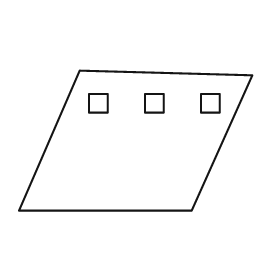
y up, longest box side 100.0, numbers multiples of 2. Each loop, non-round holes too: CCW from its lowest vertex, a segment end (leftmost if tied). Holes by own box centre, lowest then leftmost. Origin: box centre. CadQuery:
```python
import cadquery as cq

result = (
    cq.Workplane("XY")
    .moveTo(-50.0, -30.0)
    .lineTo(24.0, -30.0)
    .lineTo(50.0, 28.0)
    .lineTo(-24.0, 30.0)
    .close()
    .moveTo(-20.0, 12.0)
    .lineTo(-12.0, 12.0)
    .lineTo(-12.0, 20.0)
    .lineTo(-20.0, 20.0)
    .close()
    .moveTo(4.0, 12.0)
    .lineTo(12.0, 12.0)
    .lineTo(12.0, 20.0)
    .lineTo(4.0, 20.0)
    .close()
    .moveTo(28.0, 12.0)
    .lineTo(36.0, 12.0)
    .lineTo(36.0, 20.0)
    .lineTo(28.0, 20.0)
    .close()
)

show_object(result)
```